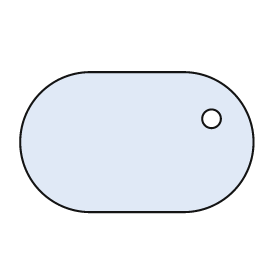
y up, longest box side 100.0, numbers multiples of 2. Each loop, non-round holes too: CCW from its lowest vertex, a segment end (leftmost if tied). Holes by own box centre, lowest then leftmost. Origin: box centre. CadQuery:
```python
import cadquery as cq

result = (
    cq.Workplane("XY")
    .moveTo(-20.0, -30.0)
    .lineTo(20.0, -30.0)
    .threePointArc((50.0, 0.0), (20.0, 30.0))
    .lineTo(-20.0, 30.0)
    .threePointArc((-50.0, 0.0), (-20.0, -30.0))
    .close()
    .moveTo(32.0, 10.0)
    .circle(4.0)
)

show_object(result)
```